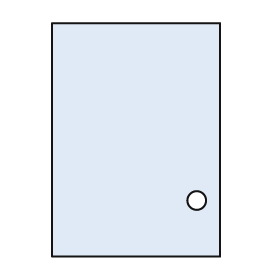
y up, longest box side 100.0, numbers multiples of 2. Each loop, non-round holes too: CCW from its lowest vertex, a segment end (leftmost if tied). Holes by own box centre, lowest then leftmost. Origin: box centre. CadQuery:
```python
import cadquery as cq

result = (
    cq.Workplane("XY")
    .moveTo(-36.0, -50.0)
    .lineTo(36.0, -50.0)
    .lineTo(36.0, 50.0)
    .lineTo(-36.0, 50.0)
    .close()
    .moveTo(26.0, -26.0)
    .circle(4.0)
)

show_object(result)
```